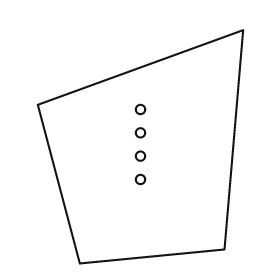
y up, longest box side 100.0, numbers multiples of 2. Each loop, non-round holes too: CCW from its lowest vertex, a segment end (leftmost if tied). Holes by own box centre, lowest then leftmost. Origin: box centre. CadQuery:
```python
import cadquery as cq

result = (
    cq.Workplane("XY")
    .moveTo(-26.0, -50.0)
    .lineTo(36.0, -44.0)
    .lineTo(44.0, 50.0)
    .lineTo(-44.0, 18.0)
    .close()
    .moveTo(0.0, -14.0)
    .circle(2.0)
    .moveTo(0.0, -4.0)
    .circle(2.0)
    .moveTo(0.0, 6.0)
    .circle(2.0)
    .moveTo(0.0, 16.0)
    .circle(2.0)
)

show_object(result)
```